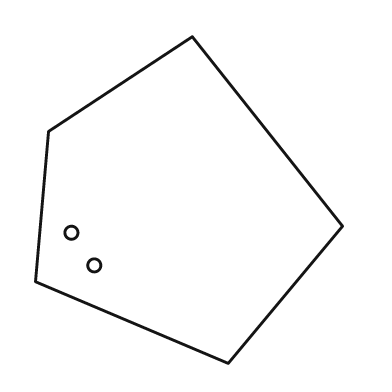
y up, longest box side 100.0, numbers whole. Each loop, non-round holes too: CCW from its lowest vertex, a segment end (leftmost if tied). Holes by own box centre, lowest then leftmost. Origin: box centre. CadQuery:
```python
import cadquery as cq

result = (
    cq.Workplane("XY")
    .moveTo(12.0, -50.0)
    .lineTo(47.0, -8.0)
    .lineTo(1.0, 50.0)
    .lineTo(-43.0, 21.0)
    .lineTo(-47.0, -25.0)
    .close()
    .moveTo(-29.0, -20.0)
    .circle(2.0)
    .moveTo(-36.0, -10.0)
    .circle(2.0)
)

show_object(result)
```